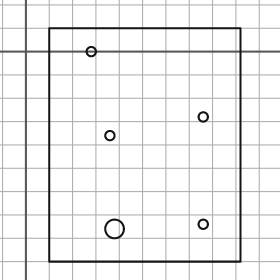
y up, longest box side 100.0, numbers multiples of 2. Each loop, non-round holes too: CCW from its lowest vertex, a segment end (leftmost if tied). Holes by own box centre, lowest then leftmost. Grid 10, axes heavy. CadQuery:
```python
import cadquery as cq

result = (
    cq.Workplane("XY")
    .moveTo(10.0, -90.0)
    .lineTo(92.0, -90.0)
    .lineTo(92.0, 10.0)
    .lineTo(10.0, 10.0)
    .close()
    .moveTo(38.0, -76.0)
    .circle(4.0)
    .moveTo(76.0, -74.0)
    .circle(2.0)
    .moveTo(36.0, -36.0)
    .circle(2.0)
    .moveTo(76.0, -28.0)
    .circle(2.0)
    .moveTo(28.0, 0.0)
    .circle(2.0)
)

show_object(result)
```